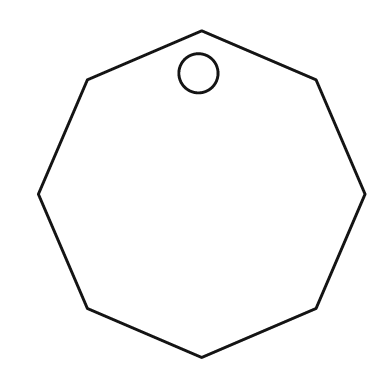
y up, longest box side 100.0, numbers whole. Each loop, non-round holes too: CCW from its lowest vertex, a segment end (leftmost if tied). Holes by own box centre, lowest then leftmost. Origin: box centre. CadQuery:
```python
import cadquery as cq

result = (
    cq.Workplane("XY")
    .moveTo(0.0, -50.0)
    .lineTo(35.0, -35.0)
    .lineTo(50.0, 0.0)
    .lineTo(35.0, 35.0)
    .lineTo(0.0, 50.0)
    .lineTo(-35.0, 35.0)
    .lineTo(-50.0, 0.0)
    .lineTo(-35.0, -35.0)
    .close()
    .moveTo(-1.0, 37.0)
    .circle(6.0)
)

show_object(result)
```